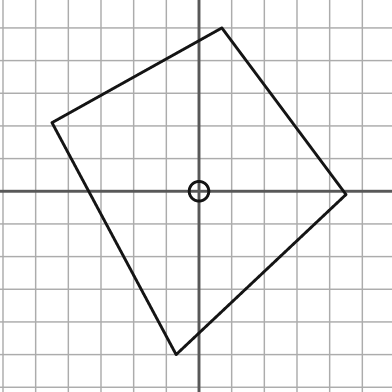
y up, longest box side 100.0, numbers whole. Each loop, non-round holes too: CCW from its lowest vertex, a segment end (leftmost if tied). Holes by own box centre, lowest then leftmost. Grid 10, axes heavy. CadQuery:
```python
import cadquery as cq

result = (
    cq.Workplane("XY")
    .moveTo(-7.0, -50.0)
    .lineTo(45.0, -1.0)
    .lineTo(7.0, 50.0)
    .lineTo(-45.0, 21.0)
    .close()
    .moveTo(0.0, 0.0)
    .circle(3.0)
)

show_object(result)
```